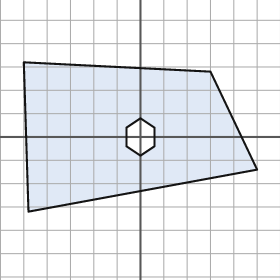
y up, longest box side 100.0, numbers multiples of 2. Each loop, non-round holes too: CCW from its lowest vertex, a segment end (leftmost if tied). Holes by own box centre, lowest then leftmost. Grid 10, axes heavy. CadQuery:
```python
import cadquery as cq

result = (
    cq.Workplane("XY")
    .moveTo(-48.0, -32.0)
    .lineTo(50.0, -14.0)
    .lineTo(30.0, 28.0)
    .lineTo(-50.0, 32.0)
    .close()
    .moveTo(0.0, -8.0)
    .lineTo(6.0, -4.0)
    .lineTo(6.0, 4.0)
    .lineTo(0.0, 8.0)
    .lineTo(-6.0, 4.0)
    .lineTo(-6.0, -4.0)
    .close()
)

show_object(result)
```